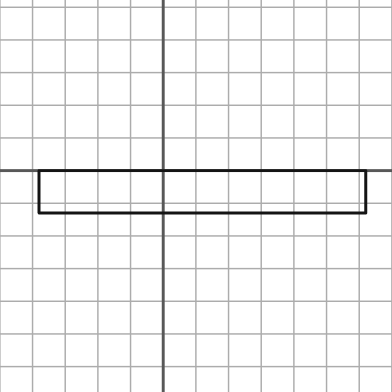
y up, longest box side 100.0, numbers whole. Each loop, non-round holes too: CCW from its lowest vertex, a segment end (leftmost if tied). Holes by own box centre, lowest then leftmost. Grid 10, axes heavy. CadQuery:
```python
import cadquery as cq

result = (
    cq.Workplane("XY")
    .moveTo(-38.0, -13.0)
    .lineTo(62.0, -13.0)
    .lineTo(62.0, 0.0)
    .lineTo(-38.0, 0.0)
    .close()
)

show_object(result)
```